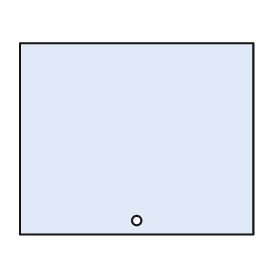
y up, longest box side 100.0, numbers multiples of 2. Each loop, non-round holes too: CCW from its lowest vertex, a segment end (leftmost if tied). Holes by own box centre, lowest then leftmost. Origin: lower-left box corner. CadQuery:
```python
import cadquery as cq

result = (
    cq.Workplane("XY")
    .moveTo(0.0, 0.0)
    .lineTo(100.0, 0.0)
    .lineTo(100.0, 82.0)
    .lineTo(0.0, 82.0)
    .close()
    .moveTo(50.0, 6.0)
    .circle(2.0)
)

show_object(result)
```